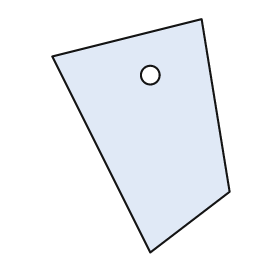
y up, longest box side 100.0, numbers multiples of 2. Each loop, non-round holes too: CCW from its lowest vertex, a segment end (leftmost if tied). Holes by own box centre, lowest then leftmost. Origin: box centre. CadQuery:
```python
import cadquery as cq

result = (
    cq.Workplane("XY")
    .moveTo(4.0, -50.0)
    .lineTo(38.0, -24.0)
    .lineTo(26.0, 50.0)
    .lineTo(-38.0, 34.0)
    .close()
    .moveTo(4.0, 26.0)
    .circle(4.0)
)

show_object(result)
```